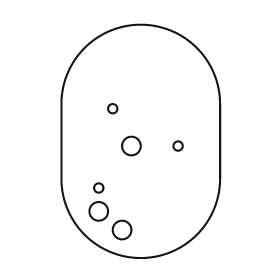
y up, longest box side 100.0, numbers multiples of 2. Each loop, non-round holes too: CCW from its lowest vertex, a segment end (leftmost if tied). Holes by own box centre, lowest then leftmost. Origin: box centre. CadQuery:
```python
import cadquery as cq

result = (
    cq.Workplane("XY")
    .moveTo(-34.0, -16.0)
    .threePointArc((0.0, -50.0), (34.0, -16.0))
    .lineTo(34.0, 16.0)
    .threePointArc((0.0, 50.0), (-34.0, 16.0))
    .close()
    .moveTo(-8.0, -38.0)
    .circle(4.0)
    .moveTo(-18.0, -30.0)
    .circle(4.0)
    .moveTo(-18.0, -20.0)
    .circle(2.0)
    .moveTo(-4.0, -2.0)
    .circle(4.0)
    .moveTo(16.0, -2.0)
    .circle(2.0)
    .moveTo(-12.0, 14.0)
    .circle(2.0)
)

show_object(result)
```